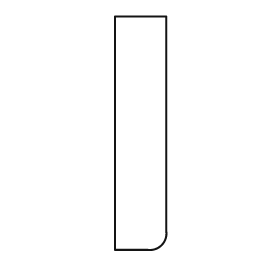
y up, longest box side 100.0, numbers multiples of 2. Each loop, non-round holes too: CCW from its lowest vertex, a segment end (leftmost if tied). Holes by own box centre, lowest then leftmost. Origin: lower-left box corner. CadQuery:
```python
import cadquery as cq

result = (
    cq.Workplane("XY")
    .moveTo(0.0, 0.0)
    .lineTo(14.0, 0.0)
    .threePointArc((20.0, 2.0), (22.0, 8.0))
    .lineTo(22.0, 100.0)
    .lineTo(0.0, 100.0)
    .close()
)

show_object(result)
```